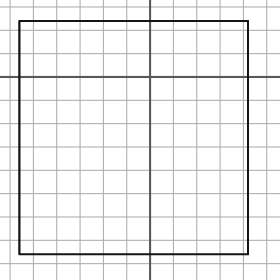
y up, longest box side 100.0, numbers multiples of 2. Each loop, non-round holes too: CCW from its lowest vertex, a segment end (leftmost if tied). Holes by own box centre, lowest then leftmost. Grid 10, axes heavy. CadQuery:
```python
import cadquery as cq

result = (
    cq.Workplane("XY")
    .moveTo(-56.0, -76.0)
    .lineTo(42.0, -76.0)
    .lineTo(42.0, 24.0)
    .lineTo(-56.0, 24.0)
    .close()
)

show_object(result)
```